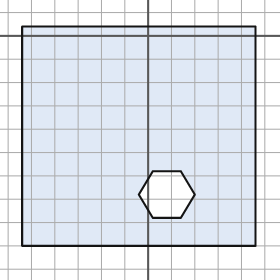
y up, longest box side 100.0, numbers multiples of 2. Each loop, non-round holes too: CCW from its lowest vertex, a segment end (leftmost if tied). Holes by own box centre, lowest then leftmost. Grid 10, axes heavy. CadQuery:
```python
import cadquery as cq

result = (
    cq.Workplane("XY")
    .moveTo(-54.0, -90.0)
    .lineTo(46.0, -90.0)
    .lineTo(46.0, 4.0)
    .lineTo(-54.0, 4.0)
    .close()
    .moveTo(2.0, -78.0)
    .lineTo(14.0, -78.0)
    .lineTo(20.0, -68.0)
    .lineTo(14.0, -58.0)
    .lineTo(2.0, -58.0)
    .lineTo(-4.0, -68.0)
    .close()
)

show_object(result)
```